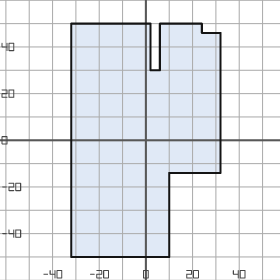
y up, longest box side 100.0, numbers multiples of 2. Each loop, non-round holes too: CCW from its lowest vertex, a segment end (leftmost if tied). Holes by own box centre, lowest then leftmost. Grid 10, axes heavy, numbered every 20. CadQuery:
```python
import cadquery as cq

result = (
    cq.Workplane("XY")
    .moveTo(-32.0, -50.0)
    .lineTo(10.0, -50.0)
    .lineTo(10.0, -14.0)
    .lineTo(32.0, -14.0)
    .lineTo(32.0, 46.0)
    .lineTo(24.0, 46.0)
    .lineTo(24.0, 50.0)
    .lineTo(6.0, 50.0)
    .lineTo(6.0, 30.0)
    .lineTo(2.0, 30.0)
    .lineTo(2.0, 50.0)
    .lineTo(-32.0, 50.0)
    .close()
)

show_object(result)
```